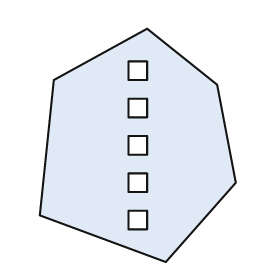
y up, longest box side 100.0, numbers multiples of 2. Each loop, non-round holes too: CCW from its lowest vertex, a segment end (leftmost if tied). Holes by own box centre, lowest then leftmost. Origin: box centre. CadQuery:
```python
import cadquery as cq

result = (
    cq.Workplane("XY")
    .moveTo(12.0, -50.0)
    .lineTo(42.0, -16.0)
    .lineTo(34.0, 26.0)
    .lineTo(4.0, 50.0)
    .lineTo(-36.0, 28.0)
    .lineTo(-42.0, -30.0)
    .close()
    .moveTo(-4.0, -36.0)
    .lineTo(4.0, -36.0)
    .lineTo(4.0, -28.0)
    .lineTo(-4.0, -28.0)
    .close()
    .moveTo(-4.0, -20.0)
    .lineTo(4.0, -20.0)
    .lineTo(4.0, -12.0)
    .lineTo(-4.0, -12.0)
    .close()
    .moveTo(-4.0, -4.0)
    .lineTo(4.0, -4.0)
    .lineTo(4.0, 4.0)
    .lineTo(-4.0, 4.0)
    .close()
    .moveTo(-4.0, 12.0)
    .lineTo(4.0, 12.0)
    .lineTo(4.0, 20.0)
    .lineTo(-4.0, 20.0)
    .close()
    .moveTo(-4.0, 28.0)
    .lineTo(4.0, 28.0)
    .lineTo(4.0, 36.0)
    .lineTo(-4.0, 36.0)
    .close()
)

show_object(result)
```